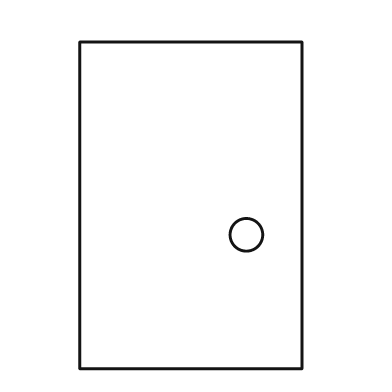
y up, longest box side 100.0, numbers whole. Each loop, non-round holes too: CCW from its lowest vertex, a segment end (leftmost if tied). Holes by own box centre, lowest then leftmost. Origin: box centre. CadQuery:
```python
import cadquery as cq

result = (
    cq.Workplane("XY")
    .moveTo(-34.0, -50.0)
    .lineTo(34.0, -50.0)
    .lineTo(34.0, 50.0)
    .lineTo(-34.0, 50.0)
    .close()
    .moveTo(17.0, -9.0)
    .circle(5.0)
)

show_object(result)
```